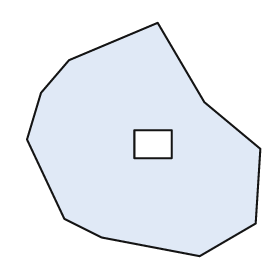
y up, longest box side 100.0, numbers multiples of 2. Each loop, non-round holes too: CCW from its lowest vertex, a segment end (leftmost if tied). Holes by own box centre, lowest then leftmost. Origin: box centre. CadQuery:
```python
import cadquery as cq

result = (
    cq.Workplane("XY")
    .moveTo(24.0, -50.0)
    .lineTo(48.0, -36.0)
    .lineTo(50.0, -4.0)
    .lineTo(26.0, 16.0)
    .lineTo(6.0, 50.0)
    .lineTo(-32.0, 34.0)
    .lineTo(-44.0, 20.0)
    .lineTo(-50.0, 0.0)
    .lineTo(-34.0, -34.0)
    .lineTo(-18.0, -42.0)
    .close()
    .moveTo(-4.0, -8.0)
    .lineTo(12.0, -8.0)
    .lineTo(12.0, 4.0)
    .lineTo(-4.0, 4.0)
    .close()
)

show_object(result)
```